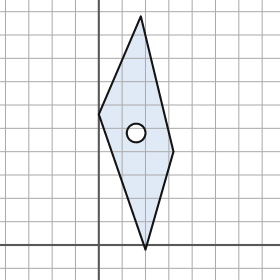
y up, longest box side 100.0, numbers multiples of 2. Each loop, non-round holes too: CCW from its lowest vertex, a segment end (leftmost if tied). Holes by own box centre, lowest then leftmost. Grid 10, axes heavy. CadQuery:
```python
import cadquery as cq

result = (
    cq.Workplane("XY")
    .moveTo(20.0, -2.0)
    .lineTo(32.0, 40.0)
    .lineTo(18.0, 98.0)
    .lineTo(0.0, 56.0)
    .close()
    .moveTo(16.0, 48.0)
    .circle(4.0)
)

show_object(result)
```